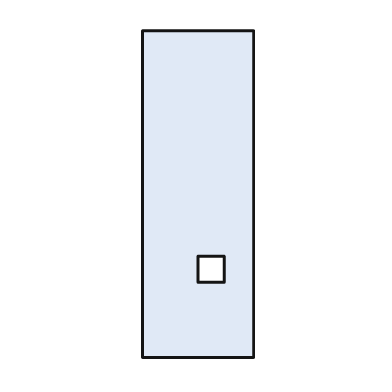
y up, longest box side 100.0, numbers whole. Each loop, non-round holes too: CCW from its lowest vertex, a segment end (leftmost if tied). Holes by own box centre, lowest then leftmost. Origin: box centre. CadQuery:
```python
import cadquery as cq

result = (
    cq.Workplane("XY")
    .moveTo(-17.0, -50.0)
    .lineTo(17.0, -50.0)
    .lineTo(17.0, 50.0)
    .lineTo(-17.0, 50.0)
    .close()
    .moveTo(0.0, -27.0)
    .lineTo(8.0, -27.0)
    .lineTo(8.0, -19.0)
    .lineTo(0.0, -19.0)
    .close()
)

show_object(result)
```